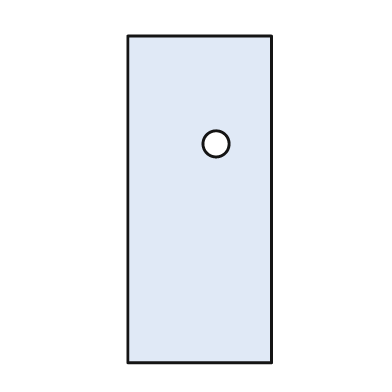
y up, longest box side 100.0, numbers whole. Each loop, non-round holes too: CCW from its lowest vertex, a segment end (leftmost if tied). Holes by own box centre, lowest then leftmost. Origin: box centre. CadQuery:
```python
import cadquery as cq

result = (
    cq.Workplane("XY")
    .moveTo(-22.0, -50.0)
    .lineTo(22.0, -50.0)
    .lineTo(22.0, 50.0)
    .lineTo(-22.0, 50.0)
    .close()
    .moveTo(5.0, 17.0)
    .circle(4.0)
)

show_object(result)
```